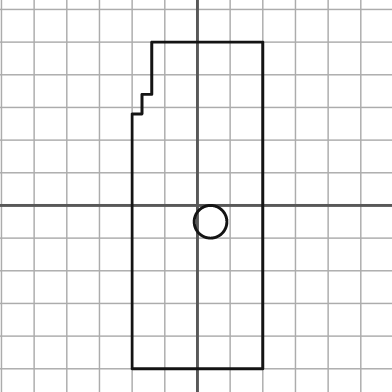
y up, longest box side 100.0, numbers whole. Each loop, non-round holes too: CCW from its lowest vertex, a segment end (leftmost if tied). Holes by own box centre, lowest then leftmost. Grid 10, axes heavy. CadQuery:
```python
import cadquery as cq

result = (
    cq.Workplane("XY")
    .moveTo(-20.0, -50.0)
    .lineTo(20.0, -50.0)
    .lineTo(20.0, 50.0)
    .lineTo(-14.0, 50.0)
    .lineTo(-14.0, 34.0)
    .lineTo(-17.0, 34.0)
    .lineTo(-17.0, 28.0)
    .lineTo(-20.0, 28.0)
    .close()
    .moveTo(4.0, -5.0)
    .circle(5.0)
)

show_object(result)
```